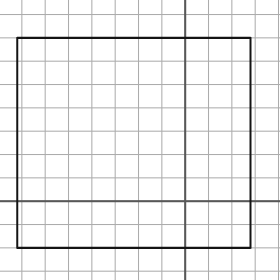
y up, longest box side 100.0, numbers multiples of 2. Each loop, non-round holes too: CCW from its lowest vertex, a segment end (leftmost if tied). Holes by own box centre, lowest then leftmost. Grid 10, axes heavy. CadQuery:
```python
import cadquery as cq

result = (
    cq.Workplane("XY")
    .moveTo(-72.0, -20.0)
    .lineTo(28.0, -20.0)
    .lineTo(28.0, 70.0)
    .lineTo(-72.0, 70.0)
    .close()
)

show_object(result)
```